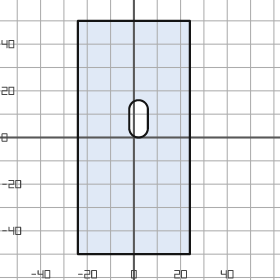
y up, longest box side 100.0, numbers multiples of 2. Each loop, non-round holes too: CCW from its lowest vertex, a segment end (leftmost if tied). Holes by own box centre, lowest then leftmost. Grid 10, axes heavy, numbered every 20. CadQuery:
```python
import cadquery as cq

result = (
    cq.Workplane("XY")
    .moveTo(-24.0, -50.0)
    .lineTo(24.0, -50.0)
    .lineTo(24.0, 50.0)
    .lineTo(-24.0, 50.0)
    .close()
    .moveTo(-2.0, 4.0)
    .threePointArc((2.0, 0.0), (6.0, 4.0))
    .lineTo(6.0, 12.0)
    .threePointArc((2.0, 16.0), (-2.0, 12.0))
    .close()
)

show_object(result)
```